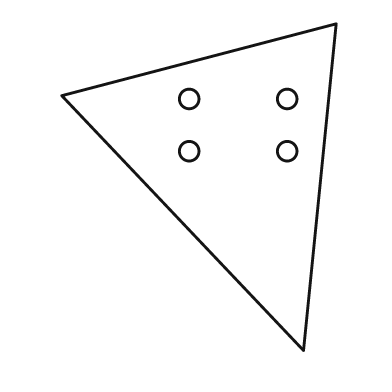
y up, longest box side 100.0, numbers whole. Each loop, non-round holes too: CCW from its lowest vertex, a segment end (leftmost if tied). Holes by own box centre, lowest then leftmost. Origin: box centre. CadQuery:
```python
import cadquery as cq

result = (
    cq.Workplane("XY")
    .moveTo(32.0, -50.0)
    .lineTo(42.0, 50.0)
    .lineTo(-42.0, 28.0)
    .close()
    .moveTo(-3.0, 11.0)
    .circle(3.0)
    .moveTo(27.0, 11.0)
    .circle(3.0)
    .moveTo(-3.0, 27.0)
    .circle(3.0)
    .moveTo(27.0, 27.0)
    .circle(3.0)
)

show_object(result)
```